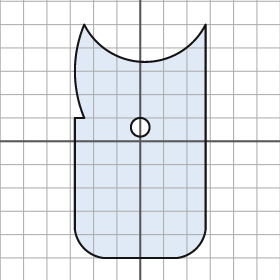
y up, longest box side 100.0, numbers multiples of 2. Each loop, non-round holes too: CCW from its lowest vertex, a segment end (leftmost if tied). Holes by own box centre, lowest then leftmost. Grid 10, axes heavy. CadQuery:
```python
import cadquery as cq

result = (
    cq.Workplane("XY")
    .moveTo(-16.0, -50.0)
    .lineTo(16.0, -50.0)
    .threePointArc((24.0, -46.0), (28.0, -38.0))
    .lineTo(28.0, 50.0)
    .threePointArc((2.0, 34.0), (-24.0, 50.0))
    .threePointArc((-28.0, 30.0), (-24.0, 10.0))
    .lineTo(-28.0, 10.0)
    .lineTo(-28.0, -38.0)
    .threePointArc((-24.0, -46.0), (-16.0, -50.0))
    .close()
    .moveTo(0.0, 6.0)
    .circle(4.0)
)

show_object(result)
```